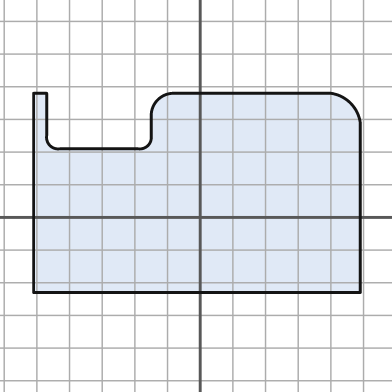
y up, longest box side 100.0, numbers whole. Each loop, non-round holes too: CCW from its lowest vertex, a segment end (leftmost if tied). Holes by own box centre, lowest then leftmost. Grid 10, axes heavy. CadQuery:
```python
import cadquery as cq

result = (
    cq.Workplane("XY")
    .moveTo(-51.0, -23.0)
    .lineTo(49.0, -23.0)
    .lineTo(49.0, 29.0)
    .threePointArc((46.0, 35.0), (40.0, 38.0))
    .lineTo(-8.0, 38.0)
    .threePointArc((-13.0, 36.0), (-15.0, 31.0))
    .lineTo(-15.0, 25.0)
    .threePointArc((-16.0, 22.0), (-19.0, 21.0))
    .lineTo(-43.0, 21.0)
    .threePointArc((-46.0, 22.0), (-47.0, 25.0))
    .lineTo(-47.0, 38.0)
    .lineTo(-51.0, 38.0)
    .close()
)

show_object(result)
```